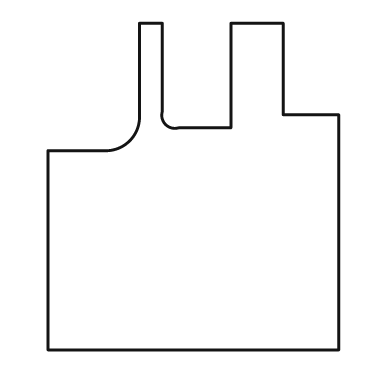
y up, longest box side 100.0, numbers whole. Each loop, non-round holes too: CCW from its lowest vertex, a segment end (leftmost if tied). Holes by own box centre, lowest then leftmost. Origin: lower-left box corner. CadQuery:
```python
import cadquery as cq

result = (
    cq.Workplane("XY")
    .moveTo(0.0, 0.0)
    .lineTo(89.0, 0.0)
    .lineTo(89.0, 72.0)
    .lineTo(72.0, 72.0)
    .lineTo(72.0, 100.0)
    .lineTo(56.0, 100.0)
    .lineTo(56.0, 68.0)
    .lineTo(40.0, 68.0)
    .threePointArc((36.0, 69.0), (35.0, 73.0))
    .lineTo(35.0, 100.0)
    .lineTo(28.0, 100.0)
    .lineTo(28.0, 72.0)
    .threePointArc((25.0, 64.0), (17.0, 61.0))
    .lineTo(0.0, 61.0)
    .close()
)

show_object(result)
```